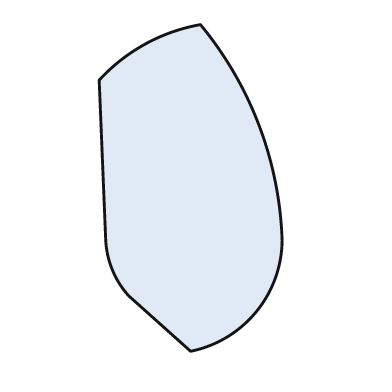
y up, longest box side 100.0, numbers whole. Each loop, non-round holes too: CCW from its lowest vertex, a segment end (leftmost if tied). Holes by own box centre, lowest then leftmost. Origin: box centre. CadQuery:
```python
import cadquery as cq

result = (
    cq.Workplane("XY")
    .moveTo(0.0, -50.0)
    .threePointArc((20.0, -38.0), (28.0, -16.0))
    .threePointArc((21.0, 19.0), (3.0, 50.0))
    .threePointArc((-14.0, 44.0), (-28.0, 33.0))
    .lineTo(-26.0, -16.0)
    .threePointArc((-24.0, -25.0), (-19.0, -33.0))
    .close()
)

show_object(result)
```